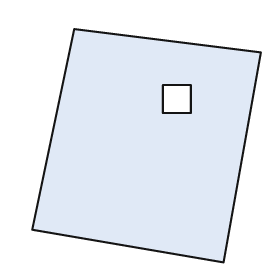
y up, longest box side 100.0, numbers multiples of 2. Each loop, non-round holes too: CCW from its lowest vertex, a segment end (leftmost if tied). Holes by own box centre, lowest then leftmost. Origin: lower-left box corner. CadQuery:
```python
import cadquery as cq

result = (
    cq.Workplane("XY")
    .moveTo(82.0, 0.0)
    .lineTo(98.0, 90.0)
    .lineTo(18.0, 100.0)
    .lineTo(0.0, 14.0)
    .close()
    .moveTo(56.0, 64.0)
    .lineTo(68.0, 64.0)
    .lineTo(68.0, 76.0)
    .lineTo(56.0, 76.0)
    .close()
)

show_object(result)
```